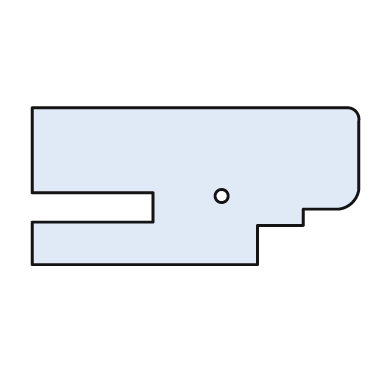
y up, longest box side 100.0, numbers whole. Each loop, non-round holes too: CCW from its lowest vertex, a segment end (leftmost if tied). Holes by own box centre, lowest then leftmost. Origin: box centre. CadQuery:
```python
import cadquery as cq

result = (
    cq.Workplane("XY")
    .moveTo(-50.0, -24.0)
    .lineTo(19.0, -24.0)
    .lineTo(19.0, -12.0)
    .lineTo(33.0, -12.0)
    .lineTo(33.0, -7.0)
    .lineTo(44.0, -7.0)
    .threePointArc((48.0, -5.0), (50.0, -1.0))
    .lineTo(50.0, 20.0)
    .threePointArc((49.0, 23.0), (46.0, 24.0))
    .lineTo(-50.0, 24.0)
    .lineTo(-50.0, -2.0)
    .lineTo(-13.0, -2.0)
    .lineTo(-13.0, -11.0)
    .lineTo(-50.0, -11.0)
    .close()
    .moveTo(8.0, -3.0)
    .circle(2.0)
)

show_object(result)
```